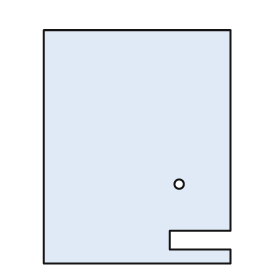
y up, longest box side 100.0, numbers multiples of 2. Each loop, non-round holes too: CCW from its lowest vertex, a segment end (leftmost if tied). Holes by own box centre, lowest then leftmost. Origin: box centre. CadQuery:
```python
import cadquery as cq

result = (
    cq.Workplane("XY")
    .moveTo(-40.0, -50.0)
    .lineTo(40.0, -50.0)
    .lineTo(40.0, -44.0)
    .lineTo(14.0, -44.0)
    .lineTo(14.0, -36.0)
    .lineTo(40.0, -36.0)
    .lineTo(40.0, 50.0)
    .lineTo(-40.0, 50.0)
    .close()
    .moveTo(18.0, -16.0)
    .circle(2.0)
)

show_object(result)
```